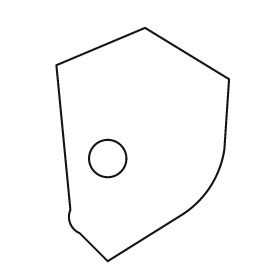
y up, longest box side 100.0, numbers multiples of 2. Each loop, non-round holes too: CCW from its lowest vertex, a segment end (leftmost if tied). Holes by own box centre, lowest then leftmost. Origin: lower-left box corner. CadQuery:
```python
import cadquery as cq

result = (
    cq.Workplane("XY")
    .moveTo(22.0, 0.0)
    .lineTo(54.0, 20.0)
    .threePointArc((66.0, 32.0), (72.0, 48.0))
    .lineTo(74.0, 78.0)
    .lineTo(38.0, 100.0)
    .lineTo(0.0, 84.0)
    .lineTo(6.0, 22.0)
    .threePointArc((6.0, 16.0), (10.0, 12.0))
    .close()
    .moveTo(22.0, 44.0)
    .circle(8.0)
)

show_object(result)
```